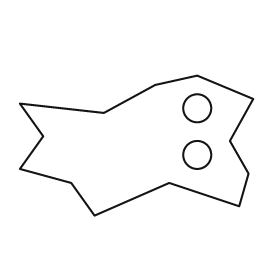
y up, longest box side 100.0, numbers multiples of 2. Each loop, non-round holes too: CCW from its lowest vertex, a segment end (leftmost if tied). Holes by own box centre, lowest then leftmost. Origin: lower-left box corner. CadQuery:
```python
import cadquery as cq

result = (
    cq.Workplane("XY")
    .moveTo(32.0, 0.0)
    .lineTo(64.0, 14.0)
    .lineTo(94.0, 4.0)
    .lineTo(98.0, 18.0)
    .lineTo(90.0, 32.0)
    .lineTo(100.0, 50.0)
    .lineTo(76.0, 60.0)
    .lineTo(58.0, 56.0)
    .lineTo(36.0, 44.0)
    .lineTo(0.0, 48.0)
    .lineTo(10.0, 34.0)
    .lineTo(0.0, 20.0)
    .lineTo(22.0, 14.0)
    .close()
    .moveTo(76.0, 26.0)
    .circle(6.0)
    .moveTo(76.0, 46.0)
    .circle(6.0)
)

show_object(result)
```